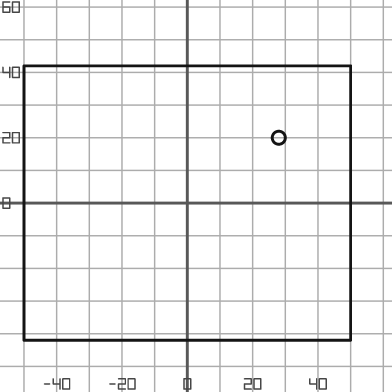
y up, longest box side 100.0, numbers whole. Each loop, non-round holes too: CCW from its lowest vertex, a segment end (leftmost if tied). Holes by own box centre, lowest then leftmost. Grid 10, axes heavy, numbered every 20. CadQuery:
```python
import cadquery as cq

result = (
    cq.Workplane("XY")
    .moveTo(-50.0, -42.0)
    .lineTo(50.0, -42.0)
    .lineTo(50.0, 42.0)
    .lineTo(-50.0, 42.0)
    .close()
    .moveTo(28.0, 20.0)
    .circle(2.0)
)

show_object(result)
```